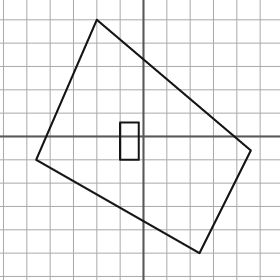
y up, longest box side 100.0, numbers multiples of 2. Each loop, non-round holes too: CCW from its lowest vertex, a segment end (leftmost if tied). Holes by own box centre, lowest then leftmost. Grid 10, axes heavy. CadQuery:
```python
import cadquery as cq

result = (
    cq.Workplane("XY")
    .moveTo(24.0, -50.0)
    .lineTo(46.0, -6.0)
    .lineTo(-20.0, 50.0)
    .lineTo(-46.0, -10.0)
    .close()
    .moveTo(-10.0, -10.0)
    .lineTo(-2.0, -10.0)
    .lineTo(-2.0, 6.0)
    .lineTo(-10.0, 6.0)
    .close()
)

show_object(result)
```